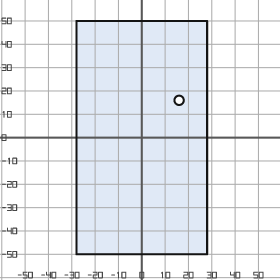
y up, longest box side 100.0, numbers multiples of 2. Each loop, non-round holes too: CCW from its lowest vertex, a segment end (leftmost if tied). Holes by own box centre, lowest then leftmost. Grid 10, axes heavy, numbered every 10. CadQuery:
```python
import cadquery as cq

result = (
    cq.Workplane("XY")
    .moveTo(-28.0, -50.0)
    .lineTo(28.0, -50.0)
    .lineTo(28.0, 50.0)
    .lineTo(-28.0, 50.0)
    .close()
    .moveTo(16.0, 16.0)
    .circle(2.0)
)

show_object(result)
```